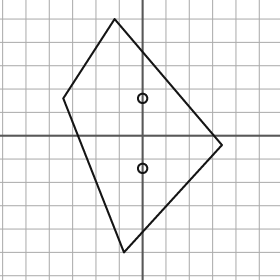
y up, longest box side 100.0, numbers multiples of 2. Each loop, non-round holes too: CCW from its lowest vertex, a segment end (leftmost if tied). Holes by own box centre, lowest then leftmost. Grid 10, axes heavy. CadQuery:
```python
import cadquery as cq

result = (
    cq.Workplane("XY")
    .moveTo(-8.0, -50.0)
    .lineTo(34.0, -4.0)
    .lineTo(-12.0, 50.0)
    .lineTo(-34.0, 16.0)
    .close()
    .moveTo(0.0, -14.0)
    .circle(2.0)
    .moveTo(0.0, 16.0)
    .circle(2.0)
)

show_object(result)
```